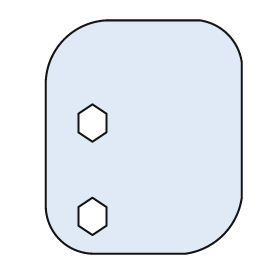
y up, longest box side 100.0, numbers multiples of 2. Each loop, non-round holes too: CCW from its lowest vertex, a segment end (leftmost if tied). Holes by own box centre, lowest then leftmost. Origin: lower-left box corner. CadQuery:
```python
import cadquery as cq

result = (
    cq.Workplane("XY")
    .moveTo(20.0, 0.0)
    .lineTo(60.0, 0.0)
    .threePointArc((76.0, 8.0), (84.0, 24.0))
    .lineTo(84.0, 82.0)
    .threePointArc((78.0, 94.0), (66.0, 100.0))
    .lineTo(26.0, 100.0)
    .threePointArc((8.0, 92.0), (0.0, 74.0))
    .lineTo(0.0, 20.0)
    .threePointArc((6.0, 6.0), (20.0, 0.0))
    .close()
    .moveTo(20.0, 8.0)
    .lineTo(26.0, 12.0)
    .lineTo(26.0, 20.0)
    .lineTo(20.0, 24.0)
    .lineTo(14.0, 20.0)
    .lineTo(14.0, 12.0)
    .close()
    .moveTo(20.0, 48.0)
    .lineTo(26.0, 52.0)
    .lineTo(26.0, 60.0)
    .lineTo(20.0, 64.0)
    .lineTo(14.0, 60.0)
    .lineTo(14.0, 52.0)
    .close()
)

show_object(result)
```